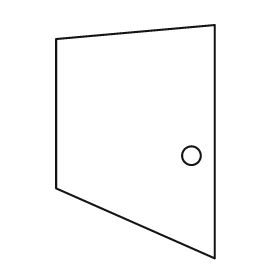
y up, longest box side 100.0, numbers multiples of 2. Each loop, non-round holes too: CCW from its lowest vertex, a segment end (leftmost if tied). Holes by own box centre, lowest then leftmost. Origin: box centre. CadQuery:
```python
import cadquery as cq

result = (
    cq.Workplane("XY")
    .moveTo(34.0, -50.0)
    .lineTo(34.0, 50.0)
    .lineTo(-34.0, 44.0)
    .lineTo(-34.0, -20.0)
    .close()
    .moveTo(24.0, -6.0)
    .circle(4.0)
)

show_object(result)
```